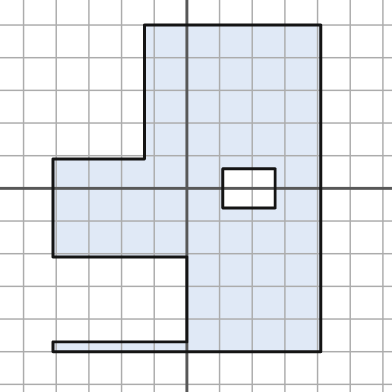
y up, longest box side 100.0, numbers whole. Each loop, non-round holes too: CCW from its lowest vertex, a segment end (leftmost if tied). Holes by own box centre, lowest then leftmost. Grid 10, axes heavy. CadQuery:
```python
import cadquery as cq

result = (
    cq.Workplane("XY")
    .moveTo(-41.0, -50.0)
    .lineTo(41.0, -50.0)
    .lineTo(41.0, 50.0)
    .lineTo(-13.0, 50.0)
    .lineTo(-13.0, 9.0)
    .lineTo(-41.0, 9.0)
    .lineTo(-41.0, -21.0)
    .lineTo(0.0, -21.0)
    .lineTo(0.0, -47.0)
    .lineTo(-41.0, -47.0)
    .close()
    .moveTo(11.0, -6.0)
    .lineTo(27.0, -6.0)
    .lineTo(27.0, 6.0)
    .lineTo(11.0, 6.0)
    .close()
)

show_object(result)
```